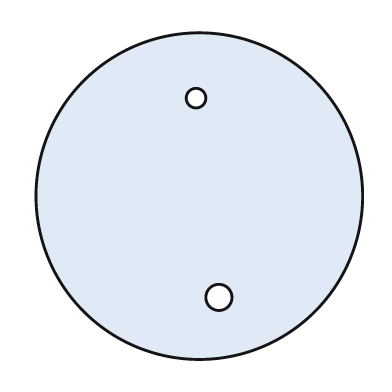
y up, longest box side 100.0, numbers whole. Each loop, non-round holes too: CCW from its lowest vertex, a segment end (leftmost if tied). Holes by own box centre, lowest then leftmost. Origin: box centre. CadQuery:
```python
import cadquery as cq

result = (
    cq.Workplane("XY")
    .moveTo(0.0, 0.0)
    .circle(50.0)
    .moveTo(6.0, -31.0)
    .circle(4.0)
    .moveTo(-1.0, 30.0)
    .circle(3.0)
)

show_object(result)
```